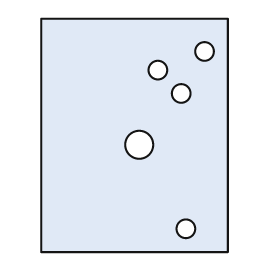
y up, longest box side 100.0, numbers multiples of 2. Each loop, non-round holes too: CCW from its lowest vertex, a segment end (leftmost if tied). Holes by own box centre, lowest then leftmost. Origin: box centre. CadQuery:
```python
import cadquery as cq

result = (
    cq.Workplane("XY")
    .moveTo(-40.0, -50.0)
    .lineTo(40.0, -50.0)
    .lineTo(40.0, 50.0)
    .lineTo(-40.0, 50.0)
    .close()
    .moveTo(22.0, -40.0)
    .circle(4.0)
    .moveTo(2.0, -4.0)
    .circle(6.0)
    .moveTo(20.0, 18.0)
    .circle(4.0)
    .moveTo(10.0, 28.0)
    .circle(4.0)
    .moveTo(30.0, 36.0)
    .circle(4.0)
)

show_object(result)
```